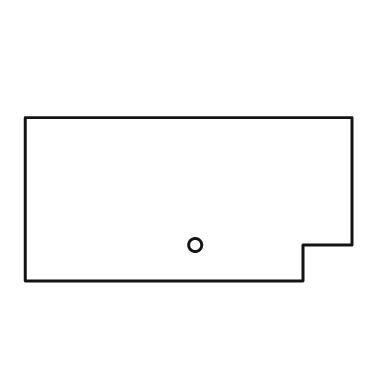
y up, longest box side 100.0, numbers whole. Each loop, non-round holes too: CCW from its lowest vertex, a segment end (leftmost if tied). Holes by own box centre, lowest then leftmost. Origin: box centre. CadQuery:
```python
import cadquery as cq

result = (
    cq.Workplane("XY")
    .moveTo(-50.0, -25.0)
    .lineTo(35.0, -25.0)
    .lineTo(35.0, -14.0)
    .lineTo(50.0, -14.0)
    .lineTo(50.0, 25.0)
    .lineTo(-50.0, 25.0)
    .close()
    .moveTo(2.0, -14.0)
    .circle(2.0)
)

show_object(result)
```